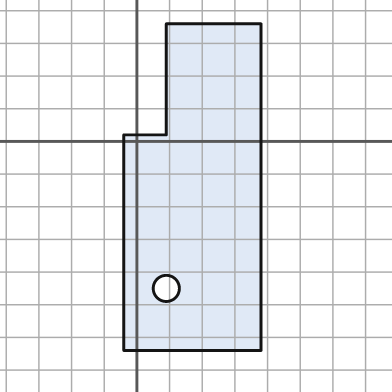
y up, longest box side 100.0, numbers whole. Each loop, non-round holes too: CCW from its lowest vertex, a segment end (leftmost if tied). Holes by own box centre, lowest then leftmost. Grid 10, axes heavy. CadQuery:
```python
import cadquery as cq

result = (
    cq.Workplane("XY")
    .moveTo(-4.0, -64.0)
    .lineTo(38.0, -64.0)
    .lineTo(38.0, 36.0)
    .lineTo(9.0, 36.0)
    .lineTo(9.0, 2.0)
    .lineTo(-4.0, 2.0)
    .close()
    .moveTo(9.0, -45.0)
    .circle(4.0)
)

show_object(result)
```